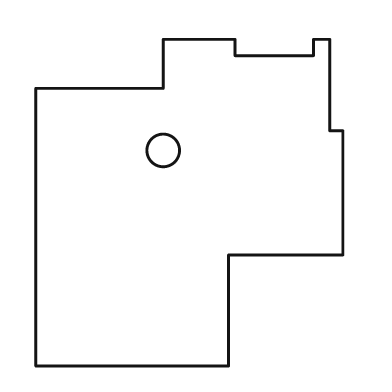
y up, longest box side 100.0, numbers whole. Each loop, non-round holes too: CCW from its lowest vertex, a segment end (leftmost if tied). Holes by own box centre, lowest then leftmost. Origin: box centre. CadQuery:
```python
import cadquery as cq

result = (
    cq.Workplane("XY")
    .moveTo(-47.0, -50.0)
    .lineTo(12.0, -50.0)
    .lineTo(12.0, -16.0)
    .lineTo(47.0, -16.0)
    .lineTo(47.0, 22.0)
    .lineTo(43.0, 22.0)
    .lineTo(43.0, 50.0)
    .lineTo(38.0, 50.0)
    .lineTo(38.0, 45.0)
    .lineTo(14.0, 45.0)
    .lineTo(14.0, 50.0)
    .lineTo(-8.0, 50.0)
    .lineTo(-8.0, 35.0)
    .lineTo(-47.0, 35.0)
    .close()
    .moveTo(-8.0, 16.0)
    .circle(5.0)
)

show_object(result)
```